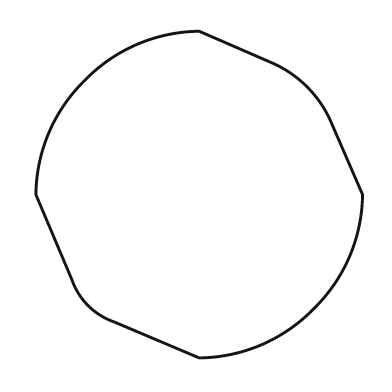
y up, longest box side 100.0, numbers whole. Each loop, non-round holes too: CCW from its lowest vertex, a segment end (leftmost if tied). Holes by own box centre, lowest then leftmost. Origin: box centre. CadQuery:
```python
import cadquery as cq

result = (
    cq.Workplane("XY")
    .moveTo(0.0, -50.0)
    .threePointArc((19.0, -46.0), (35.0, -35.0))
    .threePointArc((46.0, -19.0), (50.0, 0.0))
    .lineTo(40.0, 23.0)
    .threePointArc((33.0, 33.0), (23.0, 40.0))
    .lineTo(0.0, 50.0)
    .threePointArc((-19.0, 46.0), (-35.0, 35.0))
    .threePointArc((-46.0, 19.0), (-50.0, 0.0))
    .lineTo(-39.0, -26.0)
    .threePointArc((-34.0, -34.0), (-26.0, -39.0))
    .close()
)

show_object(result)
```